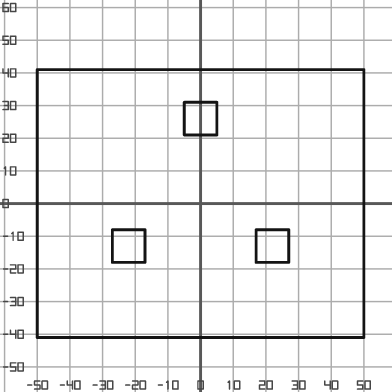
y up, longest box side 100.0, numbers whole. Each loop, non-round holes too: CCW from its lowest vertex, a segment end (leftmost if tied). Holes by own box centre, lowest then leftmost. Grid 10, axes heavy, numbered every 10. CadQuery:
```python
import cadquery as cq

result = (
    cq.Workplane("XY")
    .moveTo(-50.0, -41.0)
    .lineTo(50.0, -41.0)
    .lineTo(50.0, 41.0)
    .lineTo(-50.0, 41.0)
    .close()
    .moveTo(-27.0, -18.0)
    .lineTo(-17.0, -18.0)
    .lineTo(-17.0, -8.0)
    .lineTo(-27.0, -8.0)
    .close()
    .moveTo(17.0, -18.0)
    .lineTo(27.0, -18.0)
    .lineTo(27.0, -8.0)
    .lineTo(17.0, -8.0)
    .close()
    .moveTo(-5.0, 21.0)
    .lineTo(5.0, 21.0)
    .lineTo(5.0, 31.0)
    .lineTo(-5.0, 31.0)
    .close()
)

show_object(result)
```